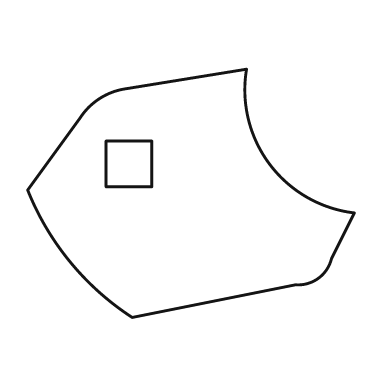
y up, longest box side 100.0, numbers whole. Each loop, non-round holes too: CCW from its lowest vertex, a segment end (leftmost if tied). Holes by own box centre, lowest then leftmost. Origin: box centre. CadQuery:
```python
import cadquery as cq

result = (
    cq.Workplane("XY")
    .moveTo(-18.0, -38.0)
    .lineTo(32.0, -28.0)
    .threePointArc((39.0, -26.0), (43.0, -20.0))
    .lineTo(50.0, -6.0)
    .threePointArc((24.0, 9.0), (17.0, 38.0))
    .lineTo(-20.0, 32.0)
    .threePointArc((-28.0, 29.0), (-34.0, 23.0))
    .lineTo(-50.0, 1.0)
    .threePointArc((-37.0, -21.0), (-18.0, -38.0))
    .close()
    .moveTo(-26.0, 2.0)
    .lineTo(-12.0, 2.0)
    .lineTo(-12.0, 16.0)
    .lineTo(-26.0, 16.0)
    .close()
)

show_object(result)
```